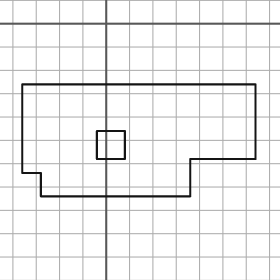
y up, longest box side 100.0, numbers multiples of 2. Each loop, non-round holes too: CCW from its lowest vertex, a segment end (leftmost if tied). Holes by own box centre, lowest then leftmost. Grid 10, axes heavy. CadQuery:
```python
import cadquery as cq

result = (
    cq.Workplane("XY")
    .moveTo(-28.0, -74.0)
    .lineTo(36.0, -74.0)
    .lineTo(36.0, -58.0)
    .lineTo(64.0, -58.0)
    .lineTo(64.0, -26.0)
    .lineTo(-36.0, -26.0)
    .lineTo(-36.0, -64.0)
    .lineTo(-28.0, -64.0)
    .close()
    .moveTo(-4.0, -58.0)
    .lineTo(8.0, -58.0)
    .lineTo(8.0, -46.0)
    .lineTo(-4.0, -46.0)
    .close()
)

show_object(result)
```